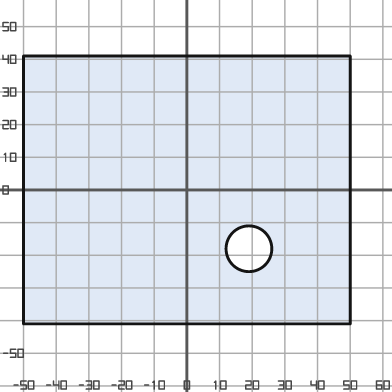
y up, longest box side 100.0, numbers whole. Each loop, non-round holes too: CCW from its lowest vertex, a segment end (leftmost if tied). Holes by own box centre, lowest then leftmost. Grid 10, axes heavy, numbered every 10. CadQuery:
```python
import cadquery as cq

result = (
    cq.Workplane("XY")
    .moveTo(-50.0, -41.0)
    .lineTo(50.0, -41.0)
    .lineTo(50.0, 41.0)
    .lineTo(-50.0, 41.0)
    .close()
    .moveTo(19.0, -18.0)
    .circle(7.0)
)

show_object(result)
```